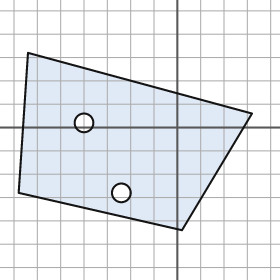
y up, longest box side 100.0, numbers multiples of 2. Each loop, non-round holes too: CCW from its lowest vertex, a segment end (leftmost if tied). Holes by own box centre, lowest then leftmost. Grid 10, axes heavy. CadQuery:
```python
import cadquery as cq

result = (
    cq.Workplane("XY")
    .moveTo(2.0, -44.0)
    .lineTo(32.0, 6.0)
    .lineTo(-64.0, 32.0)
    .lineTo(-68.0, -28.0)
    .close()
    .moveTo(-24.0, -28.0)
    .circle(4.0)
    .moveTo(-40.0, 2.0)
    .circle(4.0)
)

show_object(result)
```